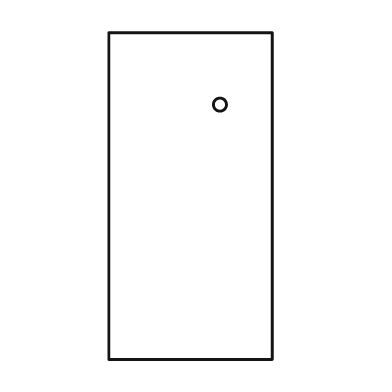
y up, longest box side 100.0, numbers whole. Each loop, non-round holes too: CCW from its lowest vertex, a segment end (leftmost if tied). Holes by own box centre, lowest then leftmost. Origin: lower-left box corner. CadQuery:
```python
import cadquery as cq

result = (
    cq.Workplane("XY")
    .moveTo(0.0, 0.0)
    .lineTo(50.0, 0.0)
    .lineTo(50.0, 100.0)
    .lineTo(0.0, 100.0)
    .close()
    .moveTo(34.0, 78.0)
    .circle(2.0)
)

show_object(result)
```